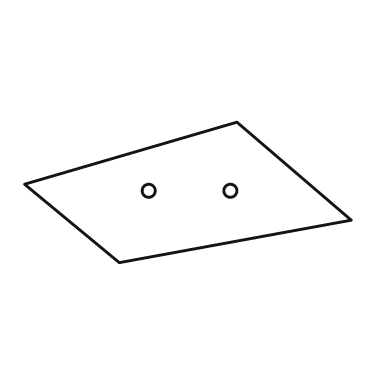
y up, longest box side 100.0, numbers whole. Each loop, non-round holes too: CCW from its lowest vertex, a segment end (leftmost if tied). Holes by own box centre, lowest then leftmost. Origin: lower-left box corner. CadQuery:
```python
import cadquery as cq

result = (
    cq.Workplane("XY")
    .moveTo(29.0, 0.0)
    .lineTo(100.0, 13.0)
    .lineTo(65.0, 43.0)
    .lineTo(0.0, 24.0)
    .close()
    .moveTo(38.0, 22.0)
    .circle(2.0)
    .moveTo(63.0, 22.0)
    .circle(2.0)
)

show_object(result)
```